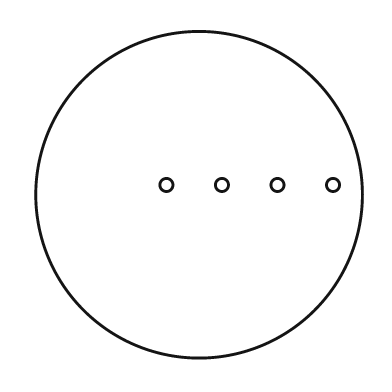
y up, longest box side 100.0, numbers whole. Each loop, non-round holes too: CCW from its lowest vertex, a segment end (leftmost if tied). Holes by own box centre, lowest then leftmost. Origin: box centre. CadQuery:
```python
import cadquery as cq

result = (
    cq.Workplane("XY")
    .moveTo(0.0, 0.0)
    .circle(50.0)
    .moveTo(-10.0, 3.0)
    .circle(2.0)
    .moveTo(7.0, 3.0)
    .circle(2.0)
    .moveTo(24.0, 3.0)
    .circle(2.0)
    .moveTo(41.0, 3.0)
    .circle(2.0)
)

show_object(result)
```